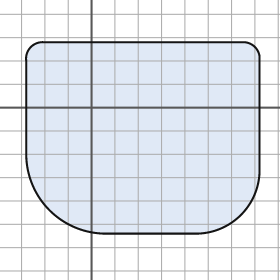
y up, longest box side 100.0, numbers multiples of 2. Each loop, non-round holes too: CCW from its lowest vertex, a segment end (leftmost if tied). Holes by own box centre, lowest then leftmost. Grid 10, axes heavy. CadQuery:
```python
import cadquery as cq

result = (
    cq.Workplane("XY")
    .moveTo(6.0, -54.0)
    .lineTo(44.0, -54.0)
    .threePointArc((64.0, -46.0), (72.0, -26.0))
    .lineTo(72.0, 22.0)
    .threePointArc((70.0, 26.0), (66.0, 28.0))
    .lineTo(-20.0, 28.0)
    .threePointArc((-26.0, 26.0), (-28.0, 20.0))
    .lineTo(-28.0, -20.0)
    .threePointArc((-18.0, -44.0), (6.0, -54.0))
    .close()
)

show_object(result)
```